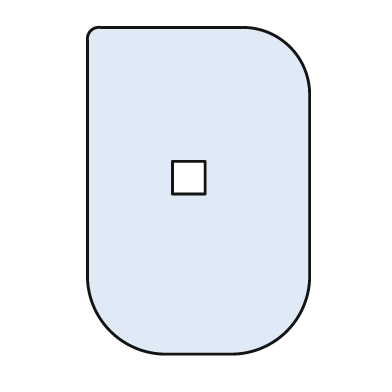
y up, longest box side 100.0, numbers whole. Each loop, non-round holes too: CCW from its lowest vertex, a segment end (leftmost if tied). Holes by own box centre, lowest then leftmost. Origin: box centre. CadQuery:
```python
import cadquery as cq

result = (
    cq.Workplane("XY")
    .moveTo(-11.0, -50.0)
    .lineTo(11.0, -50.0)
    .threePointArc((27.0, -43.0), (34.0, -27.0))
    .lineTo(34.0, 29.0)
    .threePointArc((28.0, 44.0), (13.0, 50.0))
    .lineTo(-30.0, 50.0)
    .threePointArc((-33.0, 49.0), (-34.0, 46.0))
    .lineTo(-34.0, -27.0)
    .threePointArc((-27.0, -43.0), (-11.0, -50.0))
    .close()
    .moveTo(-8.0, -1.0)
    .lineTo(2.0, -1.0)
    .lineTo(2.0, 9.0)
    .lineTo(-8.0, 9.0)
    .close()
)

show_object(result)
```